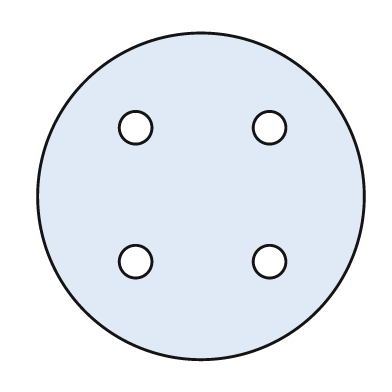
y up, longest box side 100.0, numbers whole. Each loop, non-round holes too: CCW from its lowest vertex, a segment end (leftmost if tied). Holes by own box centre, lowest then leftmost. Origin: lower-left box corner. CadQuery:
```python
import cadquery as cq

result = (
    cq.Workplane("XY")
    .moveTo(50.0, 50.0)
    .circle(50.0)
    .moveTo(30.0, 30.0)
    .circle(5.0)
    .moveTo(71.0, 30.0)
    .circle(5.0)
    .moveTo(30.0, 71.0)
    .circle(5.0)
    .moveTo(71.0, 71.0)
    .circle(5.0)
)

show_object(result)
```